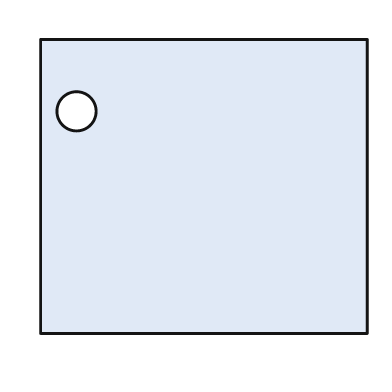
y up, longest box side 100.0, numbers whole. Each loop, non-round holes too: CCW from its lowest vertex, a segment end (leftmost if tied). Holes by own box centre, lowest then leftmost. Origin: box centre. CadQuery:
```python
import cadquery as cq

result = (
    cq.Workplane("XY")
    .moveTo(-50.0, -45.0)
    .lineTo(50.0, -45.0)
    .lineTo(50.0, 45.0)
    .lineTo(-50.0, 45.0)
    .close()
    .moveTo(-39.0, 23.0)
    .circle(6.0)
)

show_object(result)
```